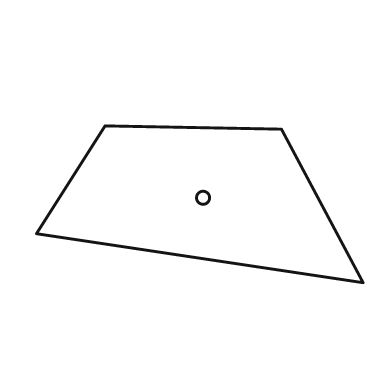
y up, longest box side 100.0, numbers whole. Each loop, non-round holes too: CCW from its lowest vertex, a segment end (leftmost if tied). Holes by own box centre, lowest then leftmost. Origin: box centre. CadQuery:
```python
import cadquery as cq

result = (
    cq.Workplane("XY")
    .moveTo(50.0, -24.0)
    .lineTo(25.0, 23.0)
    .lineTo(-29.0, 24.0)
    .lineTo(-50.0, -9.0)
    .close()
    .moveTo(1.0, 2.0)
    .circle(2.0)
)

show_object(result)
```